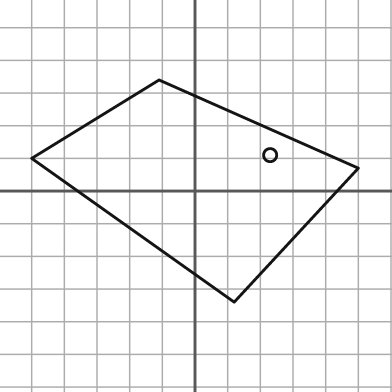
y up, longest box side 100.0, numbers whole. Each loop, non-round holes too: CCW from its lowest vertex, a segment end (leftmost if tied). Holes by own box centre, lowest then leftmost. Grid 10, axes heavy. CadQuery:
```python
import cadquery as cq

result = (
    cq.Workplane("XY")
    .moveTo(12.0, -34.0)
    .lineTo(50.0, 7.0)
    .lineTo(-11.0, 34.0)
    .lineTo(-50.0, 10.0)
    .close()
    .moveTo(23.0, 11.0)
    .circle(2.0)
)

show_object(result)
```